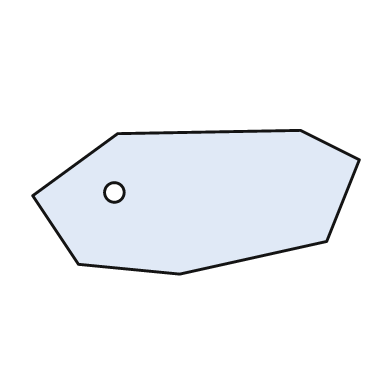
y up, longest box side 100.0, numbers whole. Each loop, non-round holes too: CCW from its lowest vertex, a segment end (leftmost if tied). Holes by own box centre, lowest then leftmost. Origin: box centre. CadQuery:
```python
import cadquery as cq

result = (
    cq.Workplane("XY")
    .moveTo(-5.0, -22.0)
    .lineTo(40.0, -12.0)
    .lineTo(50.0, 13.0)
    .lineTo(32.0, 22.0)
    .lineTo(-24.0, 21.0)
    .lineTo(-50.0, 2.0)
    .lineTo(-36.0, -19.0)
    .close()
    .moveTo(-25.0, 3.0)
    .circle(3.0)
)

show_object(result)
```